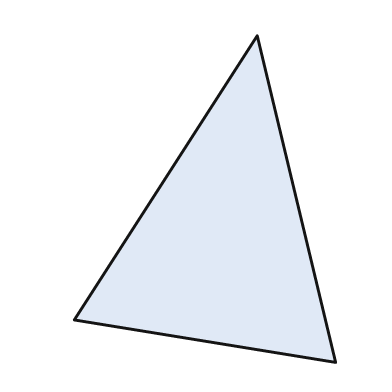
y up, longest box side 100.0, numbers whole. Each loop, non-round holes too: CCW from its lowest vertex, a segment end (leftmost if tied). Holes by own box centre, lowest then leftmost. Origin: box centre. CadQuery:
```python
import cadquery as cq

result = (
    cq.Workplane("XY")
    .moveTo(40.0, -50.0)
    .lineTo(16.0, 50.0)
    .lineTo(-40.0, -37.0)
    .close()
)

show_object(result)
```